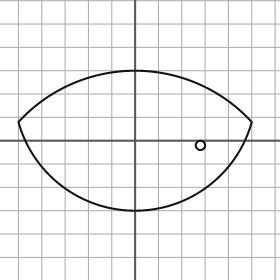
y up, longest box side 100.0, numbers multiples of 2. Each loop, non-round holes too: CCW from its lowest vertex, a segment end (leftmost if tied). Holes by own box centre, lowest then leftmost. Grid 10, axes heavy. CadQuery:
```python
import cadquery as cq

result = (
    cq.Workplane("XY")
    .moveTo(-50.0, 8.0)
    .threePointArc((0.0, -30.0), (50.0, 8.0))
    .threePointArc((0.0, 30.0), (-50.0, 8.0))
    .close()
    .moveTo(28.0, -2.0)
    .circle(2.0)
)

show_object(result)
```